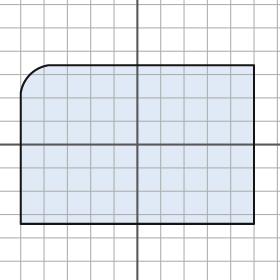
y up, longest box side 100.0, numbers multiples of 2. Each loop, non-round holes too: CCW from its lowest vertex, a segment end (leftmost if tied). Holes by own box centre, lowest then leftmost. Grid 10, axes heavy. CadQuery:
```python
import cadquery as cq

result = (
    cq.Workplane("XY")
    .moveTo(-50.0, -34.0)
    .lineTo(50.0, -34.0)
    .lineTo(50.0, 34.0)
    .lineTo(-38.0, 34.0)
    .threePointArc((-46.0, 30.0), (-50.0, 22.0))
    .close()
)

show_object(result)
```